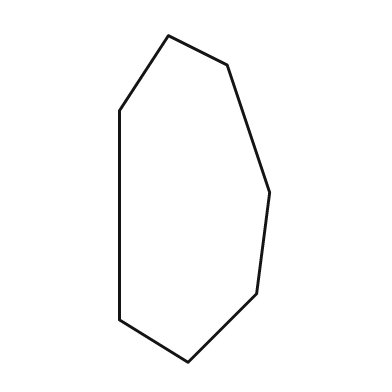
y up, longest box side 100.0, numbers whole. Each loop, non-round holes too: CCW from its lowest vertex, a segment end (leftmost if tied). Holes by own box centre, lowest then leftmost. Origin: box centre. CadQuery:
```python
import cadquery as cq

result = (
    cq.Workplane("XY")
    .moveTo(-2.0, -50.0)
    .lineTo(19.0, -29.0)
    .lineTo(23.0, 2.0)
    .lineTo(10.0, 41.0)
    .lineTo(-8.0, 50.0)
    .lineTo(-23.0, 27.0)
    .lineTo(-23.0, -37.0)
    .close()
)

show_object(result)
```